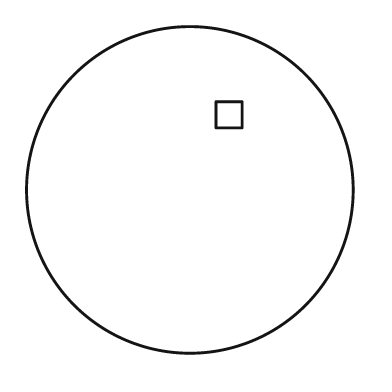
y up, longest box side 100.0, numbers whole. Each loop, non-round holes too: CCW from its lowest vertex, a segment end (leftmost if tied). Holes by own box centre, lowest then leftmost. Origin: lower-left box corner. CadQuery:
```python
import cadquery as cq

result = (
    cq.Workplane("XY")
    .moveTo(50.0, 50.0)
    .circle(50.0)
    .moveTo(58.0, 69.0)
    .lineTo(66.0, 69.0)
    .lineTo(66.0, 77.0)
    .lineTo(58.0, 77.0)
    .close()
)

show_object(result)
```